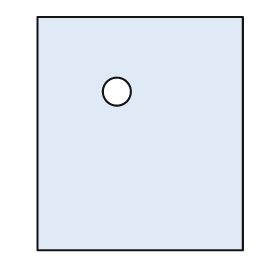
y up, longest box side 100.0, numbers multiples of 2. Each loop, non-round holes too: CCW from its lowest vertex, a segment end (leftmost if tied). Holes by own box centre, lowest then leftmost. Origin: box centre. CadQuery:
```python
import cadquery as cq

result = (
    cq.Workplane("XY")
    .moveTo(-44.0, -50.0)
    .lineTo(44.0, -50.0)
    .lineTo(44.0, 50.0)
    .lineTo(-44.0, 50.0)
    .close()
    .moveTo(-10.0, 18.0)
    .circle(6.0)
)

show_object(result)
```